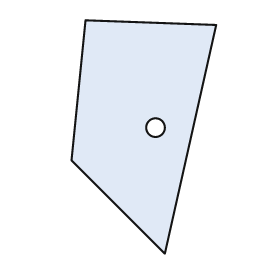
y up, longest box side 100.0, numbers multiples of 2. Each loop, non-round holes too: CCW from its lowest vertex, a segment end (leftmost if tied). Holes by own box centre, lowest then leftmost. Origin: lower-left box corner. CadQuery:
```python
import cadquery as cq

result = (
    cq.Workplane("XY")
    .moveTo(40.0, 0.0)
    .lineTo(62.0, 98.0)
    .lineTo(6.0, 100.0)
    .lineTo(0.0, 40.0)
    .close()
    .moveTo(36.0, 54.0)
    .circle(4.0)
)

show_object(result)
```